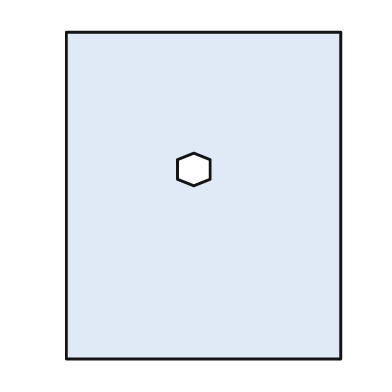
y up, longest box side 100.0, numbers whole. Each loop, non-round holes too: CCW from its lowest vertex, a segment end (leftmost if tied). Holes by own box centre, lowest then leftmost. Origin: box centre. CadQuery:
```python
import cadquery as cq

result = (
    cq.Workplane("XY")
    .moveTo(-42.0, -50.0)
    .lineTo(42.0, -50.0)
    .lineTo(42.0, 50.0)
    .lineTo(-42.0, 50.0)
    .close()
    .moveTo(-3.0, 3.0)
    .lineTo(2.0, 5.0)
    .lineTo(2.0, 11.0)
    .lineTo(-3.0, 13.0)
    .lineTo(-8.0, 11.0)
    .lineTo(-8.0, 5.0)
    .close()
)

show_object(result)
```